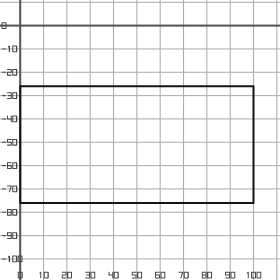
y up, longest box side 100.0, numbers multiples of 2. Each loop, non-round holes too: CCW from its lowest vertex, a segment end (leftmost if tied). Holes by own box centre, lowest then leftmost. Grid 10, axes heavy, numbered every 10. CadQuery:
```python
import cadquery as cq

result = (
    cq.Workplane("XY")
    .moveTo(0.0, -76.0)
    .lineTo(100.0, -76.0)
    .lineTo(100.0, -26.0)
    .lineTo(0.0, -26.0)
    .close()
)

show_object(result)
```